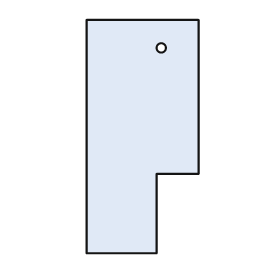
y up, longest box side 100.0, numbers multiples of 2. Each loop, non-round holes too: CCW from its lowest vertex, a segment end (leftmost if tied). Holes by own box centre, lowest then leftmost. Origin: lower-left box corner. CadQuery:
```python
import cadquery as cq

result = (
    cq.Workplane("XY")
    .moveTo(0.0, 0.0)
    .lineTo(30.0, 0.0)
    .lineTo(30.0, 34.0)
    .lineTo(48.0, 34.0)
    .lineTo(48.0, 100.0)
    .lineTo(0.0, 100.0)
    .close()
    .moveTo(32.0, 88.0)
    .circle(2.0)
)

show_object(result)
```